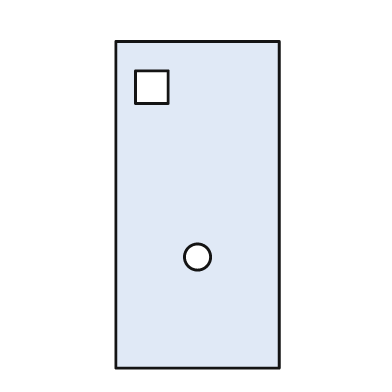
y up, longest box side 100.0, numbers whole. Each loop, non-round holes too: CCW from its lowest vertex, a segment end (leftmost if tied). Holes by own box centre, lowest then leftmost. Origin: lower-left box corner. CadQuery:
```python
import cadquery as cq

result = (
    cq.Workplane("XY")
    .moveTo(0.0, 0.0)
    .lineTo(50.0, 0.0)
    .lineTo(50.0, 100.0)
    .lineTo(0.0, 100.0)
    .close()
    .moveTo(25.0, 34.0)
    .circle(4.0)
    .moveTo(6.0, 81.0)
    .lineTo(16.0, 81.0)
    .lineTo(16.0, 91.0)
    .lineTo(6.0, 91.0)
    .close()
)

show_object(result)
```